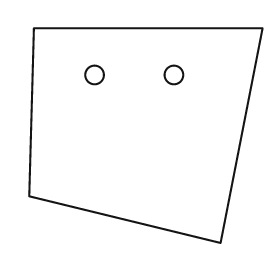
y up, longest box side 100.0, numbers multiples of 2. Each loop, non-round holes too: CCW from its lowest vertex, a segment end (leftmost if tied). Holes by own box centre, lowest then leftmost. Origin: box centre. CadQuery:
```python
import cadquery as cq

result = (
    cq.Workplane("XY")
    .moveTo(32.0, -46.0)
    .lineTo(50.0, 46.0)
    .lineTo(-48.0, 46.0)
    .lineTo(-50.0, -26.0)
    .close()
    .moveTo(-22.0, 26.0)
    .circle(4.0)
    .moveTo(12.0, 26.0)
    .circle(4.0)
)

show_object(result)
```